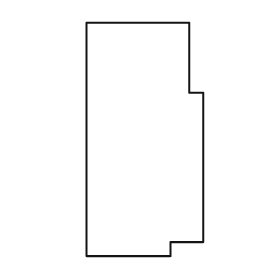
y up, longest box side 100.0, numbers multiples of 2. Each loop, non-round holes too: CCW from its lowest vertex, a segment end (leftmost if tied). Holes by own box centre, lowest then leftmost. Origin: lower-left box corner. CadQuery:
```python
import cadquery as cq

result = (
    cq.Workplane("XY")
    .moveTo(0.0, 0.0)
    .lineTo(36.0, 0.0)
    .lineTo(36.0, 6.0)
    .lineTo(50.0, 6.0)
    .lineTo(50.0, 70.0)
    .lineTo(44.0, 70.0)
    .lineTo(44.0, 100.0)
    .lineTo(0.0, 100.0)
    .close()
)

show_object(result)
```